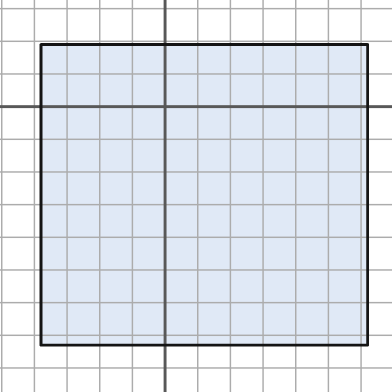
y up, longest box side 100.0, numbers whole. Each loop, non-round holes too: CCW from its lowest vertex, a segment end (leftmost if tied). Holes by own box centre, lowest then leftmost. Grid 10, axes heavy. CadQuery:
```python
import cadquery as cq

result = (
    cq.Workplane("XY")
    .moveTo(-38.0, -73.0)
    .lineTo(62.0, -73.0)
    .lineTo(62.0, 19.0)
    .lineTo(-38.0, 19.0)
    .close()
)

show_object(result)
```